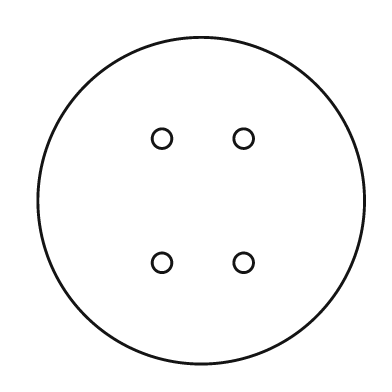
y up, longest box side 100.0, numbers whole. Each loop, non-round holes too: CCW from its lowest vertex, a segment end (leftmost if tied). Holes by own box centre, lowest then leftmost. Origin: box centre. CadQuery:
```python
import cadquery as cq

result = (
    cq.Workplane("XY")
    .moveTo(0.0, 0.0)
    .circle(50.0)
    .moveTo(-12.0, -19.0)
    .circle(3.0)
    .moveTo(13.0, -19.0)
    .circle(3.0)
    .moveTo(-12.0, 19.0)
    .circle(3.0)
    .moveTo(13.0, 19.0)
    .circle(3.0)
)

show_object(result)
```